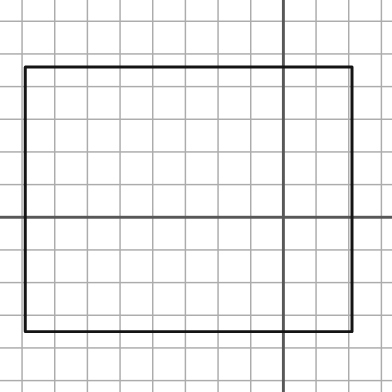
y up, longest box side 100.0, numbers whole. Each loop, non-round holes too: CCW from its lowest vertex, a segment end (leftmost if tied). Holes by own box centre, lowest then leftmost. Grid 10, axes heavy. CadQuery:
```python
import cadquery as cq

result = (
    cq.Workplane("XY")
    .moveTo(-79.0, -35.0)
    .lineTo(21.0, -35.0)
    .lineTo(21.0, 46.0)
    .lineTo(-79.0, 46.0)
    .close()
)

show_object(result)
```